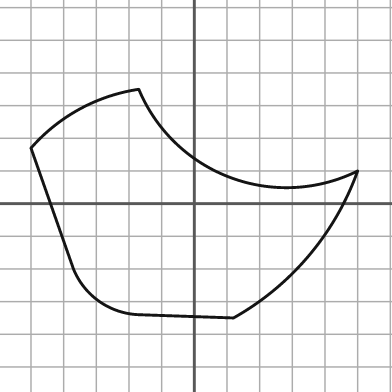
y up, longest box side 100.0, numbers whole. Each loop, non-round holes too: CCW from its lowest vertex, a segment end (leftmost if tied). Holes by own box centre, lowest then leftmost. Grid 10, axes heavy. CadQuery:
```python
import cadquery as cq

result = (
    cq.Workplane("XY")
    .moveTo(12.0, -35.0)
    .threePointArc((35.0, -16.0), (50.0, 10.0))
    .threePointArc((11.0, 8.0), (-17.0, 35.0))
    .threePointArc((-35.0, 29.0), (-50.0, 17.0))
    .lineTo(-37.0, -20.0)
    .threePointArc((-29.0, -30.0), (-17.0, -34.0))
    .close()
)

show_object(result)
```